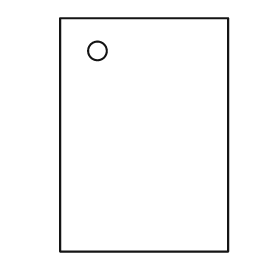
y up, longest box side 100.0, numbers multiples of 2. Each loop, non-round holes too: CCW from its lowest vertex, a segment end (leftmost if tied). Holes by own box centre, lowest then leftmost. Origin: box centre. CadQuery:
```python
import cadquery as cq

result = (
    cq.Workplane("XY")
    .moveTo(-36.0, -50.0)
    .lineTo(36.0, -50.0)
    .lineTo(36.0, 50.0)
    .lineTo(-36.0, 50.0)
    .close()
    .moveTo(-20.0, 36.0)
    .circle(4.0)
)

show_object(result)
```